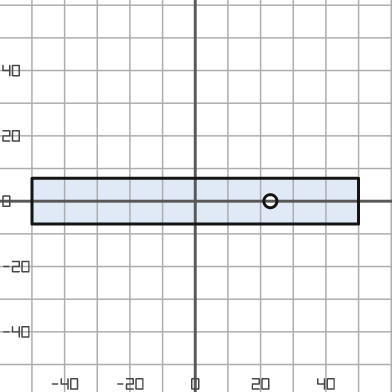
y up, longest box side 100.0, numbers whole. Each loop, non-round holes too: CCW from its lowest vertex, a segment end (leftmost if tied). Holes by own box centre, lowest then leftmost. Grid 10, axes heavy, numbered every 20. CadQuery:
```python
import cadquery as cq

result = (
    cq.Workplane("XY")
    .moveTo(-50.0, -7.0)
    .lineTo(50.0, -7.0)
    .lineTo(50.0, 7.0)
    .lineTo(-50.0, 7.0)
    .close()
    .moveTo(23.0, 0.0)
    .circle(2.0)
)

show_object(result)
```